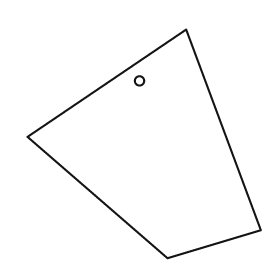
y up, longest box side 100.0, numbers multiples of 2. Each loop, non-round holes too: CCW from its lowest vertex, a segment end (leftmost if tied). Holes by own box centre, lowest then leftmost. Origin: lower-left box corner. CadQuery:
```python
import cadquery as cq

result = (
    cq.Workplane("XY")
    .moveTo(60.0, 0.0)
    .lineTo(100.0, 12.0)
    .lineTo(68.0, 98.0)
    .lineTo(0.0, 52.0)
    .close()
    .moveTo(48.0, 76.0)
    .circle(2.0)
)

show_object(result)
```